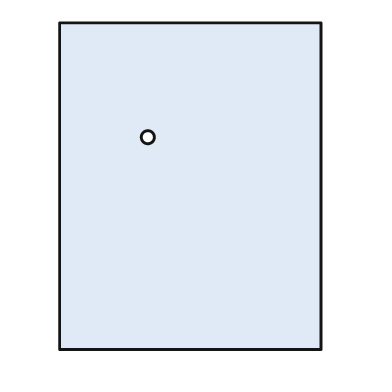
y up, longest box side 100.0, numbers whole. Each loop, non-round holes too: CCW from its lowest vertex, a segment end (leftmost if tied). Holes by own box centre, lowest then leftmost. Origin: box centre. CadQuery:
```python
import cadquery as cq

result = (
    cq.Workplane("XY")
    .moveTo(-40.0, -50.0)
    .lineTo(40.0, -50.0)
    .lineTo(40.0, 50.0)
    .lineTo(-40.0, 50.0)
    .close()
    .moveTo(-13.0, 15.0)
    .circle(2.0)
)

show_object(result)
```